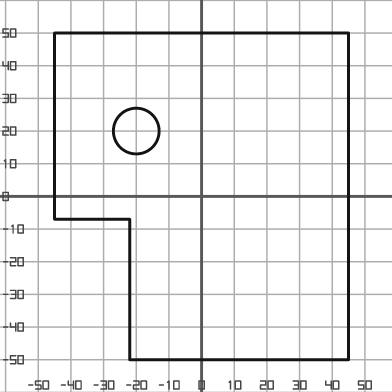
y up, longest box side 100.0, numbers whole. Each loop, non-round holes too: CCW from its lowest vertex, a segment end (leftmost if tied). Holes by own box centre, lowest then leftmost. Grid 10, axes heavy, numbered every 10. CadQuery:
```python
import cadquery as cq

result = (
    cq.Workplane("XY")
    .moveTo(-22.0, -50.0)
    .lineTo(45.0, -50.0)
    .lineTo(45.0, 50.0)
    .lineTo(-45.0, 50.0)
    .lineTo(-45.0, -7.0)
    .lineTo(-22.0, -7.0)
    .close()
    .moveTo(-20.0, 20.0)
    .circle(7.0)
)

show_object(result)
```